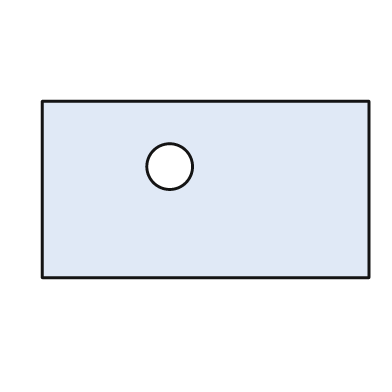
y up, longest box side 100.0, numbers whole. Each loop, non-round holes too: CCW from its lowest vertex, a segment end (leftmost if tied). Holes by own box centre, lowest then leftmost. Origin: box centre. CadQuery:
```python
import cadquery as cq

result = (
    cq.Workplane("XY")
    .moveTo(-50.0, -27.0)
    .lineTo(50.0, -27.0)
    .lineTo(50.0, 27.0)
    .lineTo(-50.0, 27.0)
    .close()
    .moveTo(-11.0, 7.0)
    .circle(7.0)
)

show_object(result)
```